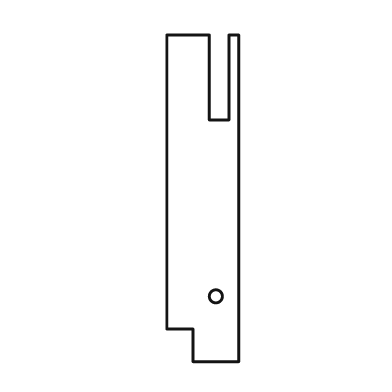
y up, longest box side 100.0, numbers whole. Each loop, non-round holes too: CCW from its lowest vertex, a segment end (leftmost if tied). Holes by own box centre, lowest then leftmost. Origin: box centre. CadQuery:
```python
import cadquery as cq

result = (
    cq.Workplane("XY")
    .moveTo(-3.0, -50.0)
    .lineTo(11.0, -50.0)
    .lineTo(11.0, 50.0)
    .lineTo(8.0, 50.0)
    .lineTo(8.0, 24.0)
    .lineTo(2.0, 24.0)
    .lineTo(2.0, 50.0)
    .lineTo(-11.0, 50.0)
    .lineTo(-11.0, -40.0)
    .lineTo(-3.0, -40.0)
    .close()
    .moveTo(4.0, -30.0)
    .circle(2.0)
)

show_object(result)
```